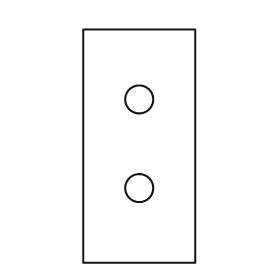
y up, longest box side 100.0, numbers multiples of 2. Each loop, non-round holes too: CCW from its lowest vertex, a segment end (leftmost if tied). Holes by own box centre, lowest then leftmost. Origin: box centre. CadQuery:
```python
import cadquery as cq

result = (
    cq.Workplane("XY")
    .moveTo(-24.0, -50.0)
    .lineTo(24.0, -50.0)
    .lineTo(24.0, 50.0)
    .lineTo(-24.0, 50.0)
    .close()
    .moveTo(0.0, -18.0)
    .circle(6.0)
    .moveTo(0.0, 20.0)
    .circle(6.0)
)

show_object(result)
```